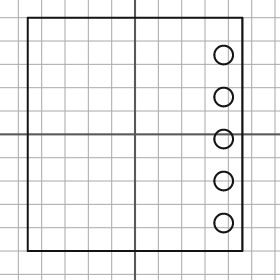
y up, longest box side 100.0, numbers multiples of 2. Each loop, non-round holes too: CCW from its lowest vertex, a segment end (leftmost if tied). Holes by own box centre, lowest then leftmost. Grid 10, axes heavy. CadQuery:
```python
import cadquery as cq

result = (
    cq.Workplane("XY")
    .moveTo(-46.0, -50.0)
    .lineTo(46.0, -50.0)
    .lineTo(46.0, 50.0)
    .lineTo(-46.0, 50.0)
    .close()
    .moveTo(38.0, -38.0)
    .circle(4.0)
    .moveTo(38.0, -20.0)
    .circle(4.0)
    .moveTo(38.0, -2.0)
    .circle(4.0)
    .moveTo(38.0, 16.0)
    .circle(4.0)
    .moveTo(38.0, 34.0)
    .circle(4.0)
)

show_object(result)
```